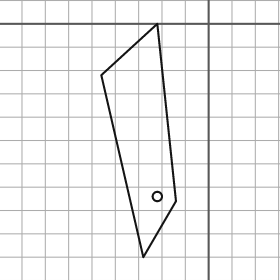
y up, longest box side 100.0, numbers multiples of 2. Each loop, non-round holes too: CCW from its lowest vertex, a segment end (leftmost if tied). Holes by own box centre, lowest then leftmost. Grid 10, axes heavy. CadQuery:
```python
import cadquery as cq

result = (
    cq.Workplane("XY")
    .moveTo(-28.0, -100.0)
    .lineTo(-14.0, -76.0)
    .lineTo(-22.0, 0.0)
    .lineTo(-46.0, -22.0)
    .close()
    .moveTo(-22.0, -74.0)
    .circle(2.0)
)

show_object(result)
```